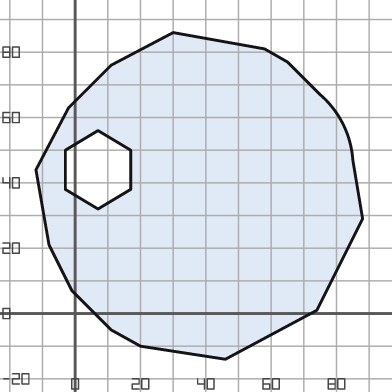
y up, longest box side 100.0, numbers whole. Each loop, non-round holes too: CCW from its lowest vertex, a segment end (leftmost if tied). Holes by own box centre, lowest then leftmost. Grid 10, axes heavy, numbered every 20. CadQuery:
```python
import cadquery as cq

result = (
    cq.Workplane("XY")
    .moveTo(46.0, -14.0)
    .lineTo(74.0, 1.0)
    .lineTo(88.0, 29.0)
    .lineTo(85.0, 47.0)
    .threePointArc((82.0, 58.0), (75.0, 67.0))
    .lineTo(65.0, 77.0)
    .lineTo(58.0, 81.0)
    .lineTo(30.0, 86.0)
    .lineTo(11.0, 76.0)
    .lineTo(-2.0, 63.0)
    .lineTo(-12.0, 44.0)
    .lineTo(-8.0, 21.0)
    .lineTo(-1.0, 7.0)
    .lineTo(11.0, -5.0)
    .lineTo(20.0, -10.0)
    .close()
    .moveTo(7.0, 32.0)
    .lineTo(17.0, 38.0)
    .lineTo(17.0, 50.0)
    .lineTo(7.0, 56.0)
    .lineTo(-3.0, 50.0)
    .lineTo(-3.0, 38.0)
    .close()
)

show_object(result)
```